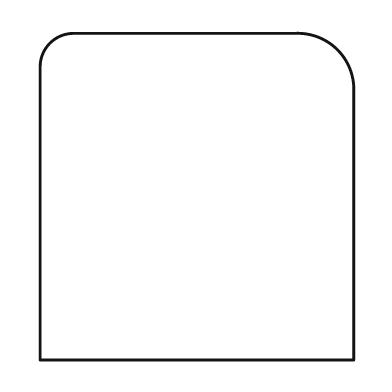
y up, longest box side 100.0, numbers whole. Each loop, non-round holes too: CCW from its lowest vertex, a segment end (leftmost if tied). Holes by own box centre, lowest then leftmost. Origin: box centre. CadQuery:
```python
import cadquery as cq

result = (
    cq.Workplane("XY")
    .moveTo(-48.0, -50.0)
    .lineTo(48.0, -50.0)
    .lineTo(48.0, 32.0)
    .threePointArc((43.0, 45.0), (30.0, 50.0))
    .lineTo(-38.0, 50.0)
    .threePointArc((-45.0, 47.0), (-48.0, 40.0))
    .close()
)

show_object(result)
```